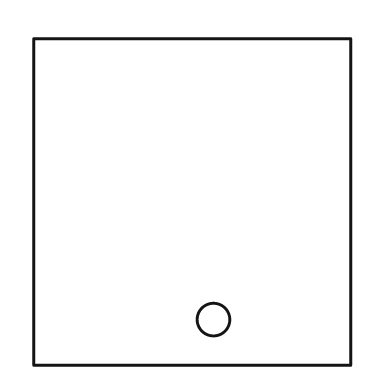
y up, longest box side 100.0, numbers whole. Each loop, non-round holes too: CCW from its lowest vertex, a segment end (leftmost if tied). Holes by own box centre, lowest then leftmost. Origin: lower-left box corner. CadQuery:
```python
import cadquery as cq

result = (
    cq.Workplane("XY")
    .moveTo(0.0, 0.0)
    .lineTo(97.0, 0.0)
    .lineTo(97.0, 100.0)
    .lineTo(0.0, 100.0)
    .close()
    .moveTo(55.0, 14.0)
    .circle(5.0)
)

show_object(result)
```